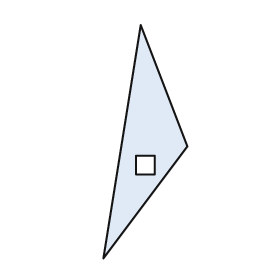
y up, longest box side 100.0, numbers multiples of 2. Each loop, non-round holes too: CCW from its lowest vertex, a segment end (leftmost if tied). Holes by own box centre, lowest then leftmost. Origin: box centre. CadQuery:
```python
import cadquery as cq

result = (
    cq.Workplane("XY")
    .moveTo(-18.0, -50.0)
    .lineTo(18.0, -2.0)
    .lineTo(-2.0, 50.0)
    .close()
    .moveTo(-4.0, -14.0)
    .lineTo(4.0, -14.0)
    .lineTo(4.0, -6.0)
    .lineTo(-4.0, -6.0)
    .close()
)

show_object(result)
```